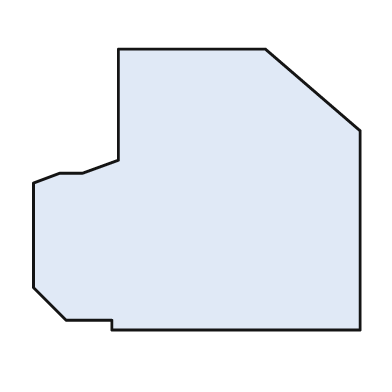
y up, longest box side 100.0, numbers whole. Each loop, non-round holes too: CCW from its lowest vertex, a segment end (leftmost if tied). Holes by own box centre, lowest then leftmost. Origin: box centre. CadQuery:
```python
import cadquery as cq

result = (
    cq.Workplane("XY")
    .moveTo(-26.0, -43.0)
    .lineTo(50.0, -43.0)
    .lineTo(50.0, 18.0)
    .lineTo(21.0, 43.0)
    .lineTo(-24.0, 43.0)
    .lineTo(-24.0, 9.0)
    .lineTo(-35.0, 5.0)
    .lineTo(-42.0, 5.0)
    .lineTo(-50.0, 2.0)
    .lineTo(-50.0, -30.0)
    .lineTo(-40.0, -40.0)
    .lineTo(-26.0, -40.0)
    .close()
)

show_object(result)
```